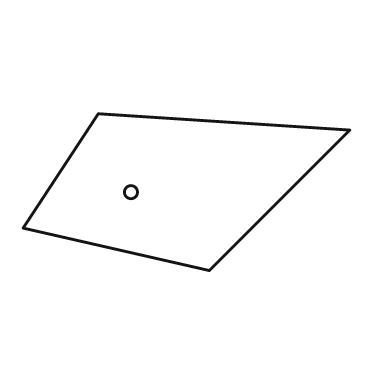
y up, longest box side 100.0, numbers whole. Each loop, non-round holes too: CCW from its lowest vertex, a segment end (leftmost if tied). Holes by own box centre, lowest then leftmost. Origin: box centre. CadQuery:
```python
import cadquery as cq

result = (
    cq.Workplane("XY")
    .moveTo(7.0, -24.0)
    .lineTo(50.0, 19.0)
    .lineTo(-27.0, 24.0)
    .lineTo(-50.0, -11.0)
    .close()
    .moveTo(-17.0, 0.0)
    .circle(2.0)
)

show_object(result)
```